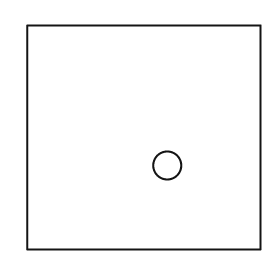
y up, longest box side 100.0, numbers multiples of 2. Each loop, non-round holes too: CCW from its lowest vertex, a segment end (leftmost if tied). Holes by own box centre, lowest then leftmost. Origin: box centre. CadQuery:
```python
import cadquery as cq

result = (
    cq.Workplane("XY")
    .moveTo(-50.0, -48.0)
    .lineTo(50.0, -48.0)
    .lineTo(50.0, 48.0)
    .lineTo(-50.0, 48.0)
    .close()
    .moveTo(10.0, -12.0)
    .circle(6.0)
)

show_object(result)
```